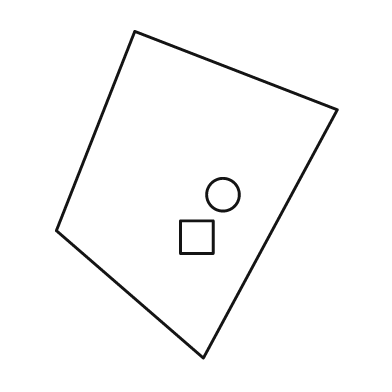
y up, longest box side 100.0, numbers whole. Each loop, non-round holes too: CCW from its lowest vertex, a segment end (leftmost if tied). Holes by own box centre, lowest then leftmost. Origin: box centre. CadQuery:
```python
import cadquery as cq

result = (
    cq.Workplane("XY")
    .moveTo(2.0, -50.0)
    .lineTo(43.0, 26.0)
    .lineTo(-19.0, 50.0)
    .lineTo(-43.0, -11.0)
    .close()
    .moveTo(-5.0, -18.0)
    .lineTo(5.0, -18.0)
    .lineTo(5.0, -8.0)
    .lineTo(-5.0, -8.0)
    .close()
    .moveTo(8.0, 0.0)
    .circle(5.0)
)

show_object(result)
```